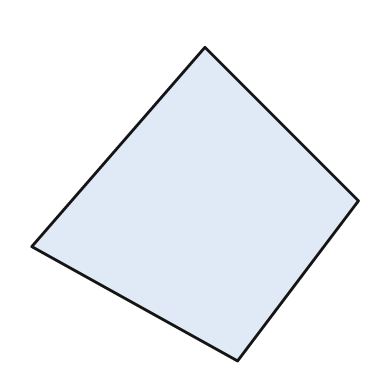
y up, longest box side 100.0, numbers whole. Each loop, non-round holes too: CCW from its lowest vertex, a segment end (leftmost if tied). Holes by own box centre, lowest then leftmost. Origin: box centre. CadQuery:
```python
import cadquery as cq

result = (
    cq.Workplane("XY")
    .moveTo(13.0, -48.0)
    .lineTo(50.0, 1.0)
    .lineTo(3.0, 48.0)
    .lineTo(-50.0, -13.0)
    .close()
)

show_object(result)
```